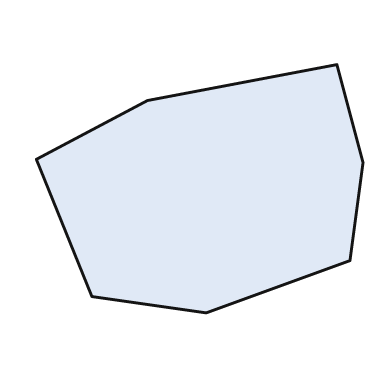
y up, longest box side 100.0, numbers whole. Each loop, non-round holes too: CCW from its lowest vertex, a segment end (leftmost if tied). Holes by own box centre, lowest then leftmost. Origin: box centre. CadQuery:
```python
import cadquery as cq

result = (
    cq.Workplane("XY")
    .moveTo(2.0, -38.0)
    .lineTo(46.0, -22.0)
    .lineTo(50.0, 8.0)
    .lineTo(42.0, 38.0)
    .lineTo(-16.0, 27.0)
    .lineTo(-50.0, 9.0)
    .lineTo(-33.0, -33.0)
    .close()
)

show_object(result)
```